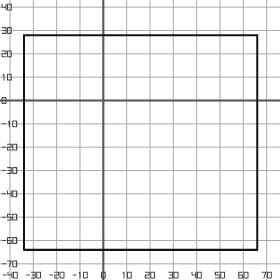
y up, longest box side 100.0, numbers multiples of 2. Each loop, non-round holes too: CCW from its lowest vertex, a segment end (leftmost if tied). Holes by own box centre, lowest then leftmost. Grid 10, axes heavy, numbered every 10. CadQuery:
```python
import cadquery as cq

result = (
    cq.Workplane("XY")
    .moveTo(-34.0, -64.0)
    .lineTo(66.0, -64.0)
    .lineTo(66.0, 28.0)
    .lineTo(-34.0, 28.0)
    .close()
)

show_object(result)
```